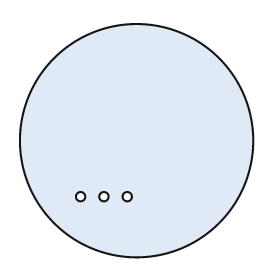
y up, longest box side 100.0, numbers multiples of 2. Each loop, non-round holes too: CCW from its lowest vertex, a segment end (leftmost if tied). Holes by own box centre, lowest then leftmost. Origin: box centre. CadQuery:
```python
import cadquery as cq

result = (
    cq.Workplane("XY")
    .moveTo(0.0, 0.0)
    .circle(50.0)
    .moveTo(-24.0, -24.0)
    .circle(2.0)
    .moveTo(-14.0, -24.0)
    .circle(2.0)
    .moveTo(-4.0, -24.0)
    .circle(2.0)
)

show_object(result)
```